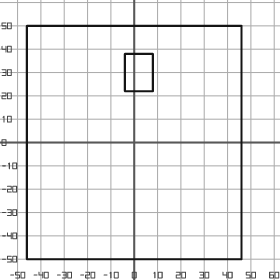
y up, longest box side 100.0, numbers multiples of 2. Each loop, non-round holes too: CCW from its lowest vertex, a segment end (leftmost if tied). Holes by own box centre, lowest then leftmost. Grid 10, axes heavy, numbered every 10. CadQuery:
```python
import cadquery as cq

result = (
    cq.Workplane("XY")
    .moveTo(-46.0, -50.0)
    .lineTo(46.0, -50.0)
    .lineTo(46.0, 50.0)
    .lineTo(-46.0, 50.0)
    .close()
    .moveTo(-4.0, 22.0)
    .lineTo(8.0, 22.0)
    .lineTo(8.0, 38.0)
    .lineTo(-4.0, 38.0)
    .close()
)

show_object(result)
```